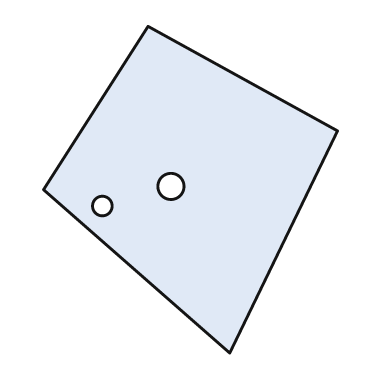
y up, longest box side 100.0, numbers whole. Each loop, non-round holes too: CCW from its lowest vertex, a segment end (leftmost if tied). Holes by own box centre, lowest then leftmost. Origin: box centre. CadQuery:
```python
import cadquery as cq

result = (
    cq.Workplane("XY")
    .moveTo(12.0, -50.0)
    .lineTo(45.0, 18.0)
    .lineTo(-13.0, 50.0)
    .lineTo(-45.0, 0.0)
    .close()
    .moveTo(-27.0, -5.0)
    .circle(3.0)
    .moveTo(-6.0, 1.0)
    .circle(4.0)
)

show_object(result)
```